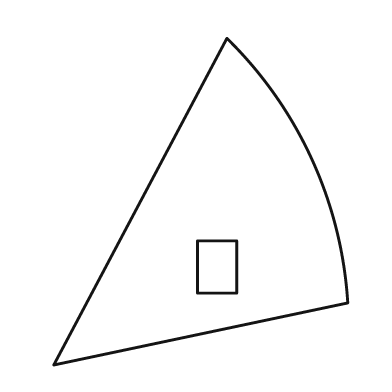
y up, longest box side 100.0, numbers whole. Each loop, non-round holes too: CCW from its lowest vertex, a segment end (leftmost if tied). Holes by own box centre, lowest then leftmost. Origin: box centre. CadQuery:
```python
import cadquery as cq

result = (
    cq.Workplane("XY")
    .moveTo(-45.0, -50.0)
    .lineTo(45.0, -31.0)
    .threePointArc((34.0, 13.0), (8.0, 50.0))
    .close()
    .moveTo(-1.0, -28.0)
    .lineTo(11.0, -28.0)
    .lineTo(11.0, -12.0)
    .lineTo(-1.0, -12.0)
    .close()
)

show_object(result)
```